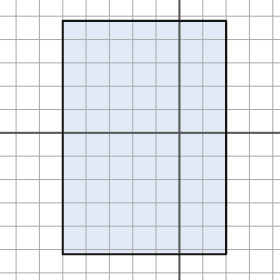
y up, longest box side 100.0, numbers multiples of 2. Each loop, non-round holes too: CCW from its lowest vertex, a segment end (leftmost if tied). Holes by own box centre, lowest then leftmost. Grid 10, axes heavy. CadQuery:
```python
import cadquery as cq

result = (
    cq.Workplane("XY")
    .moveTo(-50.0, -52.0)
    .lineTo(20.0, -52.0)
    .lineTo(20.0, 48.0)
    .lineTo(-50.0, 48.0)
    .close()
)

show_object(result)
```